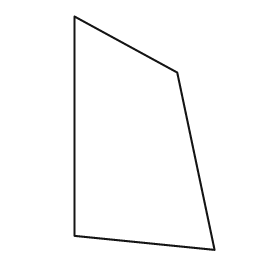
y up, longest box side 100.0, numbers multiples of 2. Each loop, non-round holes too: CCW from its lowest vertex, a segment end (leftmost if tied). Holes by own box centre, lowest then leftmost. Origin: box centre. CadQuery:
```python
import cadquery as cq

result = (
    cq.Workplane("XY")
    .moveTo(30.0, -50.0)
    .lineTo(14.0, 26.0)
    .lineTo(-30.0, 50.0)
    .lineTo(-30.0, -44.0)
    .close()
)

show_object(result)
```